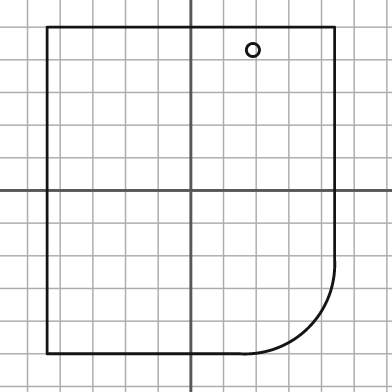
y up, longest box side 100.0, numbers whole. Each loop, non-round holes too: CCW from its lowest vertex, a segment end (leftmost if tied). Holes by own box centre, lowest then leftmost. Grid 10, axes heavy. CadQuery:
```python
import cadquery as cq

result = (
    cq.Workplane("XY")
    .moveTo(-44.0, -50.0)
    .lineTo(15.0, -50.0)
    .threePointArc((36.0, -42.0), (44.0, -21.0))
    .lineTo(44.0, 50.0)
    .lineTo(-44.0, 50.0)
    .close()
    .moveTo(19.0, 43.0)
    .circle(2.0)
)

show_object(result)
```